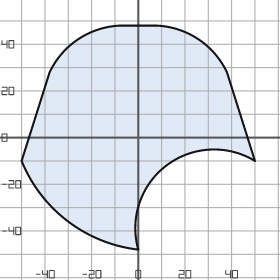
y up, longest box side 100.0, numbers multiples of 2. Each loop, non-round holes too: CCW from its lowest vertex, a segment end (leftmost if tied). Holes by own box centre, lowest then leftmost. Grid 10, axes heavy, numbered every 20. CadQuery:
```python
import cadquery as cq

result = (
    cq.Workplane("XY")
    .moveTo(0.0, -48.0)
    .threePointArc((12.0, -12.0), (50.0, -10.0))
    .lineTo(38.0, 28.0)
    .threePointArc((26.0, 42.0), (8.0, 48.0))
    .lineTo(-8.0, 48.0)
    .threePointArc((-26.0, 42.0), (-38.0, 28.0))
    .lineTo(-50.0, -10.0)
    .threePointArc((-30.0, -36.0), (0.0, -48.0))
    .close()
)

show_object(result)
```